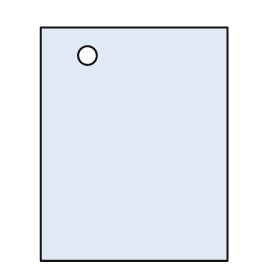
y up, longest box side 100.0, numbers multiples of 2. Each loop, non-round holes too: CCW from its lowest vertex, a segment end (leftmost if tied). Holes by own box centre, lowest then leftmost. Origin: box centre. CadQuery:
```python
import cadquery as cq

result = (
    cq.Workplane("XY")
    .moveTo(-40.0, -50.0)
    .lineTo(40.0, -50.0)
    .lineTo(40.0, 50.0)
    .lineTo(-40.0, 50.0)
    .close()
    .moveTo(-20.0, 38.0)
    .circle(4.0)
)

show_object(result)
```